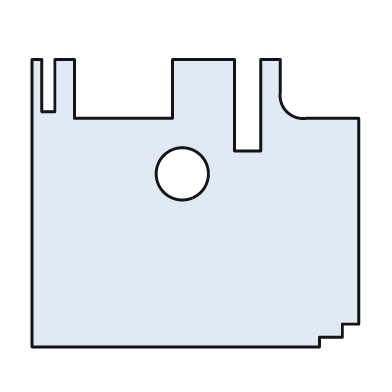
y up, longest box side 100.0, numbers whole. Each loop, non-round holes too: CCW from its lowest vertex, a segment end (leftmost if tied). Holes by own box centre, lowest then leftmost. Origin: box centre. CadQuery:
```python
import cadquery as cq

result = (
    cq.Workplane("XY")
    .moveTo(-50.0, -44.0)
    .lineTo(38.0, -44.0)
    .lineTo(38.0, -41.0)
    .lineTo(45.0, -41.0)
    .lineTo(45.0, -37.0)
    .lineTo(50.0, -37.0)
    .lineTo(50.0, 26.0)
    .lineTo(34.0, 26.0)
    .threePointArc((28.0, 28.0), (26.0, 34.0))
    .lineTo(26.0, 44.0)
    .lineTo(20.0, 44.0)
    .lineTo(20.0, 16.0)
    .lineTo(12.0, 16.0)
    .lineTo(12.0, 44.0)
    .lineTo(-7.0, 44.0)
    .lineTo(-7.0, 26.0)
    .lineTo(-37.0, 26.0)
    .lineTo(-37.0, 44.0)
    .lineTo(-43.0, 44.0)
    .lineTo(-43.0, 28.0)
    .lineTo(-47.0, 28.0)
    .lineTo(-47.0, 44.0)
    .lineTo(-50.0, 44.0)
    .close()
    .moveTo(-4.0, 9.0)
    .circle(8.0)
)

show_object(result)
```